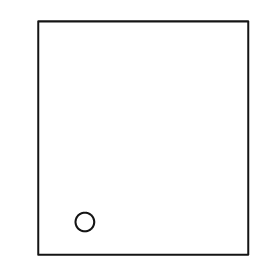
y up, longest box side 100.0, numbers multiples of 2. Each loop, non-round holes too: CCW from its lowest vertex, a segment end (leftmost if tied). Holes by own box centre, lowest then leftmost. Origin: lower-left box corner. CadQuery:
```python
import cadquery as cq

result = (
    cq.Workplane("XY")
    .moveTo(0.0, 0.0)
    .lineTo(90.0, 0.0)
    .lineTo(90.0, 100.0)
    .lineTo(0.0, 100.0)
    .close()
    .moveTo(20.0, 14.0)
    .circle(4.0)
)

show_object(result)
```